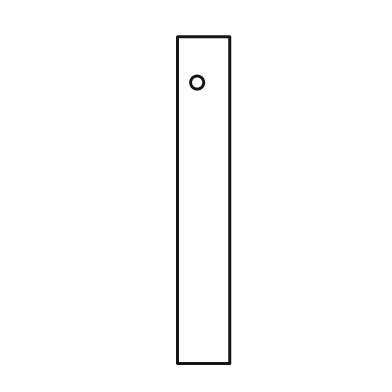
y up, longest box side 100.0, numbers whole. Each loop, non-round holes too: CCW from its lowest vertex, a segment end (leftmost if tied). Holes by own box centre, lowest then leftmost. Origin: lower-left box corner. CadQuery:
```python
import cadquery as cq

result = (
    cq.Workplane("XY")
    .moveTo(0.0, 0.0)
    .lineTo(16.0, 0.0)
    .lineTo(16.0, 100.0)
    .lineTo(0.0, 100.0)
    .close()
    .moveTo(6.0, 86.0)
    .circle(2.0)
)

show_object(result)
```